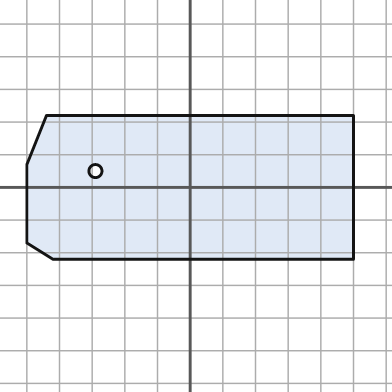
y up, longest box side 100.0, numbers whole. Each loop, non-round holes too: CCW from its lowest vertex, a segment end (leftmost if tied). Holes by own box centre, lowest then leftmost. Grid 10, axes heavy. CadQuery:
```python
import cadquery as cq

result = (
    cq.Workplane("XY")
    .moveTo(-42.0, -22.0)
    .lineTo(50.0, -22.0)
    .lineTo(50.0, 22.0)
    .lineTo(-44.0, 22.0)
    .lineTo(-50.0, 7.0)
    .lineTo(-50.0, -17.0)
    .close()
    .moveTo(-29.0, 5.0)
    .circle(2.0)
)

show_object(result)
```